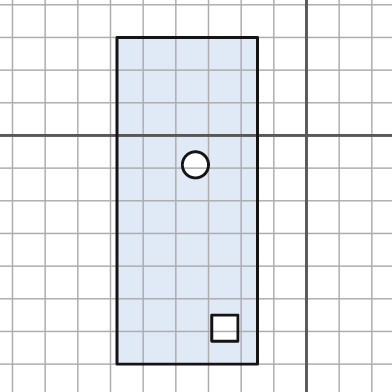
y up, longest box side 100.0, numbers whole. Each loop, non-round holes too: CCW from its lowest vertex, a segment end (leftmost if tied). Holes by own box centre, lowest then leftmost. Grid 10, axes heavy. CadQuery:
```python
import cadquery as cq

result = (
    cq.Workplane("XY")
    .moveTo(-58.0, -70.0)
    .lineTo(-15.0, -70.0)
    .lineTo(-15.0, 30.0)
    .lineTo(-58.0, 30.0)
    .close()
    .moveTo(-29.0, -63.0)
    .lineTo(-21.0, -63.0)
    .lineTo(-21.0, -55.0)
    .lineTo(-29.0, -55.0)
    .close()
    .moveTo(-34.0, -9.0)
    .circle(4.0)
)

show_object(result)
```